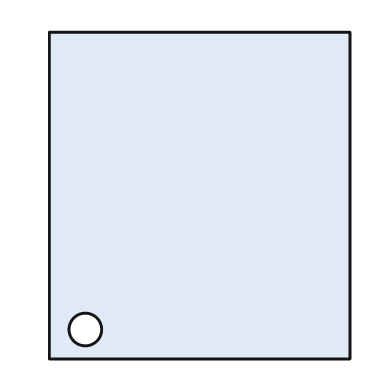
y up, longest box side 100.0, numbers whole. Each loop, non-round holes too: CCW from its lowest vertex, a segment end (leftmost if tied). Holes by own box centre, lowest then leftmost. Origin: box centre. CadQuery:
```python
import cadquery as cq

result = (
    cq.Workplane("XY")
    .moveTo(-46.0, -50.0)
    .lineTo(46.0, -50.0)
    .lineTo(46.0, 50.0)
    .lineTo(-46.0, 50.0)
    .close()
    .moveTo(-35.0, -41.0)
    .circle(5.0)
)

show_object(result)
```